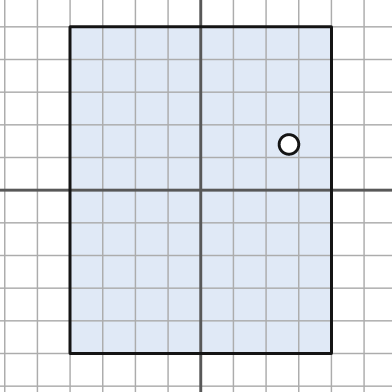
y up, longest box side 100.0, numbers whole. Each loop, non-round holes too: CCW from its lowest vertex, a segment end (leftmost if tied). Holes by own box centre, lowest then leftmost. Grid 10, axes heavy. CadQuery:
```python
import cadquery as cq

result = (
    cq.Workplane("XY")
    .moveTo(-40.0, -50.0)
    .lineTo(40.0, -50.0)
    .lineTo(40.0, 50.0)
    .lineTo(-40.0, 50.0)
    .close()
    .moveTo(27.0, 14.0)
    .circle(3.0)
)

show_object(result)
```